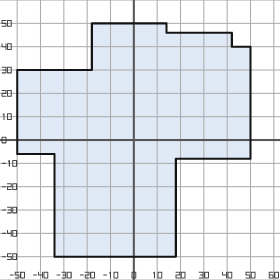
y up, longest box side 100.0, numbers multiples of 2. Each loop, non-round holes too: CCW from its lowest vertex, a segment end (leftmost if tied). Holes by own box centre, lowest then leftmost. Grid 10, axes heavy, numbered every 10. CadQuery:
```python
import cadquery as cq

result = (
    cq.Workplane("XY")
    .moveTo(-34.0, -50.0)
    .lineTo(18.0, -50.0)
    .lineTo(18.0, -8.0)
    .lineTo(50.0, -8.0)
    .lineTo(50.0, 40.0)
    .lineTo(42.0, 40.0)
    .lineTo(42.0, 46.0)
    .lineTo(14.0, 46.0)
    .lineTo(14.0, 50.0)
    .lineTo(-18.0, 50.0)
    .lineTo(-18.0, 30.0)
    .lineTo(-50.0, 30.0)
    .lineTo(-50.0, -6.0)
    .lineTo(-34.0, -6.0)
    .close()
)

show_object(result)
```